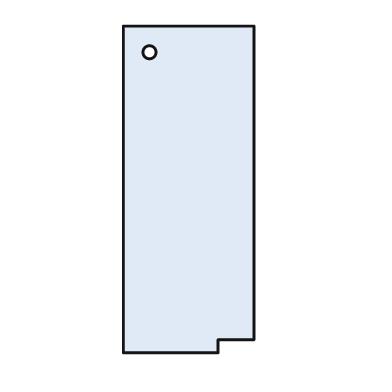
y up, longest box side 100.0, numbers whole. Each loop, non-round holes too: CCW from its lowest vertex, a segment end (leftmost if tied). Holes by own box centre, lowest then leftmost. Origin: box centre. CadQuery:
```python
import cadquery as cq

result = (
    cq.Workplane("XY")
    .moveTo(-20.0, -50.0)
    .lineTo(9.0, -50.0)
    .lineTo(9.0, -46.0)
    .lineTo(20.0, -46.0)
    .lineTo(20.0, 50.0)
    .lineTo(-20.0, 50.0)
    .close()
    .moveTo(-12.0, 42.0)
    .circle(2.0)
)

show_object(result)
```